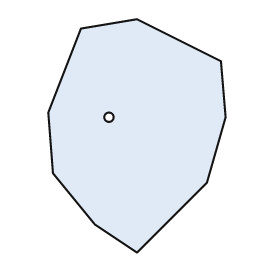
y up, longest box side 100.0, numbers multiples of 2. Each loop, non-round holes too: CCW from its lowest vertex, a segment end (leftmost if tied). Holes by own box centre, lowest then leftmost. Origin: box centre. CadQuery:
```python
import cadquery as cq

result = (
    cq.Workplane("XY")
    .moveTo(0.0, -50.0)
    .lineTo(30.0, -20.0)
    .lineTo(38.0, 8.0)
    .lineTo(36.0, 32.0)
    .lineTo(0.0, 50.0)
    .lineTo(-24.0, 46.0)
    .lineTo(-38.0, 10.0)
    .lineTo(-36.0, -16.0)
    .lineTo(-18.0, -38.0)
    .close()
    .moveTo(-12.0, 8.0)
    .circle(2.0)
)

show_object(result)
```